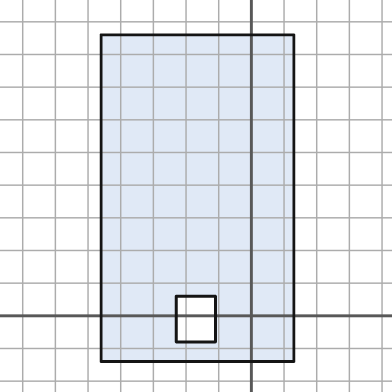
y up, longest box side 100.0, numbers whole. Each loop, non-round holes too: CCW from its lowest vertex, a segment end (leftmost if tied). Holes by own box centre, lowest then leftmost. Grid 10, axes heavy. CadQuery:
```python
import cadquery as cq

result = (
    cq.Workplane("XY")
    .moveTo(-46.0, -14.0)
    .lineTo(13.0, -14.0)
    .lineTo(13.0, 86.0)
    .lineTo(-46.0, 86.0)
    .close()
    .moveTo(-23.0, -8.0)
    .lineTo(-11.0, -8.0)
    .lineTo(-11.0, 6.0)
    .lineTo(-23.0, 6.0)
    .close()
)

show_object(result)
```